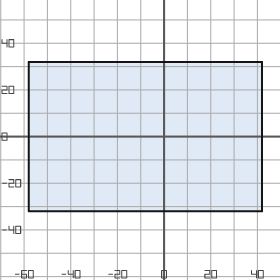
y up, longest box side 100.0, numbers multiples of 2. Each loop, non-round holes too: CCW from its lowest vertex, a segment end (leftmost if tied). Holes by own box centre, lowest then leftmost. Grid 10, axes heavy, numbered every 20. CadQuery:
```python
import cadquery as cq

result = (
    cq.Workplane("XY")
    .moveTo(-58.0, -32.0)
    .lineTo(42.0, -32.0)
    .lineTo(42.0, 32.0)
    .lineTo(-58.0, 32.0)
    .close()
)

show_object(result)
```